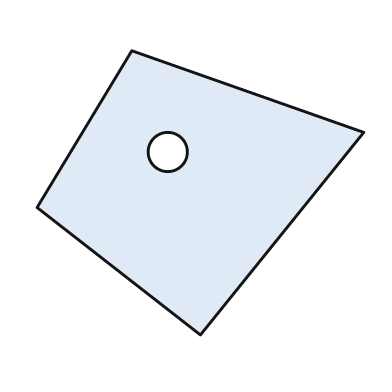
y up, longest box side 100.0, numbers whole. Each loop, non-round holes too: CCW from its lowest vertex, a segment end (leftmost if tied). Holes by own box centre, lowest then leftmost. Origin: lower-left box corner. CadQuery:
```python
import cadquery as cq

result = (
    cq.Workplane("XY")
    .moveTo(50.0, 0.0)
    .lineTo(100.0, 62.0)
    .lineTo(29.0, 87.0)
    .lineTo(0.0, 39.0)
    .close()
    .moveTo(40.0, 56.0)
    .circle(6.0)
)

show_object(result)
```